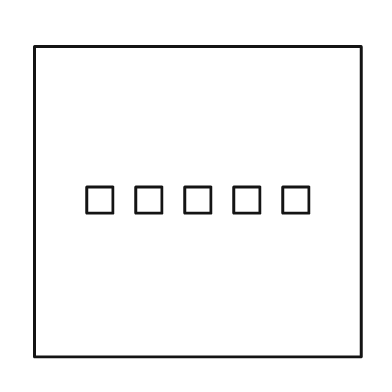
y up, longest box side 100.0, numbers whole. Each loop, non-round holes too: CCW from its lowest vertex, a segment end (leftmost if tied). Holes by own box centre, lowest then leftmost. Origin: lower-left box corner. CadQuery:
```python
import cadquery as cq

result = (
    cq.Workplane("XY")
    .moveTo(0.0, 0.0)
    .lineTo(100.0, 0.0)
    .lineTo(100.0, 95.0)
    .lineTo(0.0, 95.0)
    .close()
    .moveTo(16.0, 44.0)
    .lineTo(24.0, 44.0)
    .lineTo(24.0, 52.0)
    .lineTo(16.0, 52.0)
    .close()
    .moveTo(31.0, 44.0)
    .lineTo(39.0, 44.0)
    .lineTo(39.0, 52.0)
    .lineTo(31.0, 52.0)
    .close()
    .moveTo(46.0, 44.0)
    .lineTo(54.0, 44.0)
    .lineTo(54.0, 52.0)
    .lineTo(46.0, 52.0)
    .close()
    .moveTo(61.0, 44.0)
    .lineTo(69.0, 44.0)
    .lineTo(69.0, 52.0)
    .lineTo(61.0, 52.0)
    .close()
    .moveTo(76.0, 44.0)
    .lineTo(84.0, 44.0)
    .lineTo(84.0, 52.0)
    .lineTo(76.0, 52.0)
    .close()
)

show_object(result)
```